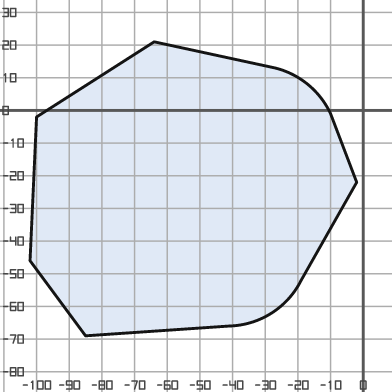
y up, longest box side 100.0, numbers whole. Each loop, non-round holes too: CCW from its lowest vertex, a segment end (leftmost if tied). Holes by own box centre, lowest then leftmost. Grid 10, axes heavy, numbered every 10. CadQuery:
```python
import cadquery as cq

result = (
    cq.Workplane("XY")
    .moveTo(-85.0, -69.0)
    .lineTo(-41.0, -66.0)
    .threePointArc((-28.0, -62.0), (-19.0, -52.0))
    .lineTo(-2.0, -22.0)
    .lineTo(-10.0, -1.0)
    .threePointArc((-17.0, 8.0), (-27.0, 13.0))
    .lineTo(-64.0, 21.0)
    .lineTo(-100.0, -2.0)
    .lineTo(-102.0, -46.0)
    .close()
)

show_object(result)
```